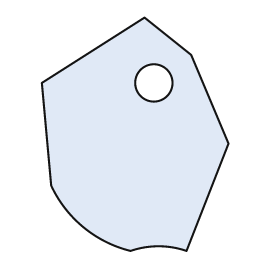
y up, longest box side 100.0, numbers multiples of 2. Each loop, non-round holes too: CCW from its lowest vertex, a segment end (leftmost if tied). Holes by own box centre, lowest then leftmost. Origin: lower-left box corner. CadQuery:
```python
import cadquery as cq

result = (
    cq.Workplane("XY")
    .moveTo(38.0, 0.0)
    .threePointArc((50.0, 2.0), (62.0, 0.0))
    .lineTo(80.0, 46.0)
    .lineTo(64.0, 84.0)
    .lineTo(44.0, 100.0)
    .lineTo(0.0, 72.0)
    .lineTo(4.0, 28.0)
    .threePointArc((18.0, 10.0), (38.0, 0.0))
    .close()
    .moveTo(48.0, 72.0)
    .circle(8.0)
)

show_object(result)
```